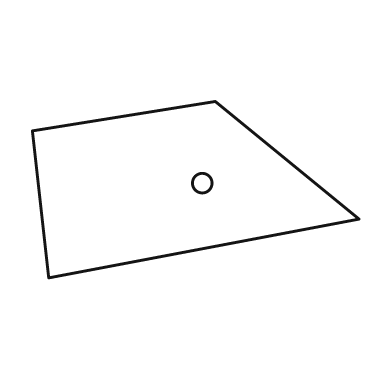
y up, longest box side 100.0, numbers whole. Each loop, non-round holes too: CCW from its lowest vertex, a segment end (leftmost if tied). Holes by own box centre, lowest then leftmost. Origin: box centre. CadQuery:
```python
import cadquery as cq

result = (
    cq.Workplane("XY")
    .moveTo(-45.0, -27.0)
    .lineTo(50.0, -9.0)
    .lineTo(6.0, 27.0)
    .lineTo(-50.0, 18.0)
    .close()
    .moveTo(2.0, 2.0)
    .circle(3.0)
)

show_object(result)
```